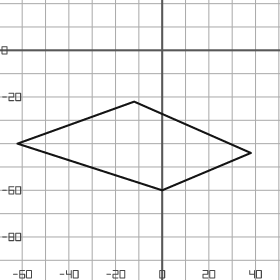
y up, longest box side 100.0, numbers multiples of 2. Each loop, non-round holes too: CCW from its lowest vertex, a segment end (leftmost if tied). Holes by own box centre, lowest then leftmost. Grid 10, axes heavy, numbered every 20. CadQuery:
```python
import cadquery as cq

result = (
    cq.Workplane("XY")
    .moveTo(0.0, -60.0)
    .lineTo(38.0, -44.0)
    .lineTo(-12.0, -22.0)
    .lineTo(-62.0, -40.0)
    .close()
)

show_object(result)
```